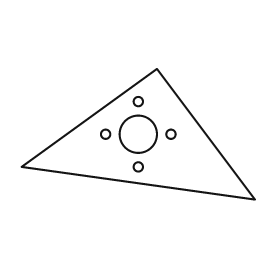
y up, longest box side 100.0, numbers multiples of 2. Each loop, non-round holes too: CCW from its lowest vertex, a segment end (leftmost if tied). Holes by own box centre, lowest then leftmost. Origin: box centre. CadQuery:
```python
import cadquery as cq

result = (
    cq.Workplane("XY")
    .moveTo(50.0, -28.0)
    .lineTo(8.0, 28.0)
    .lineTo(-50.0, -14.0)
    .close()
    .moveTo(0.0, -14.0)
    .circle(2.0)
    .moveTo(-14.0, 0.0)
    .circle(2.0)
    .moveTo(0.0, 0.0)
    .circle(8.0)
    .moveTo(14.0, 0.0)
    .circle(2.0)
    .moveTo(0.0, 14.0)
    .circle(2.0)
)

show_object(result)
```